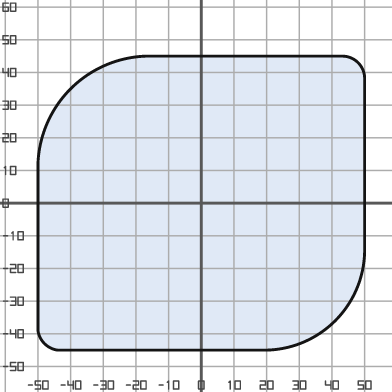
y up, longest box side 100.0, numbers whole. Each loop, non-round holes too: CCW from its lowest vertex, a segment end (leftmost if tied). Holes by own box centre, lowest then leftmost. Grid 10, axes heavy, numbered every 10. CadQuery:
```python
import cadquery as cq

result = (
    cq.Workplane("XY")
    .moveTo(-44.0, -45.0)
    .lineTo(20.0, -45.0)
    .threePointArc((41.0, -36.0), (50.0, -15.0))
    .lineTo(50.0, 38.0)
    .threePointArc((48.0, 43.0), (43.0, 45.0))
    .lineTo(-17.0, 45.0)
    .threePointArc((-40.0, 35.0), (-50.0, 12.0))
    .lineTo(-50.0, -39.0)
    .threePointArc((-48.0, -43.0), (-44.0, -45.0))
    .close()
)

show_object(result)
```